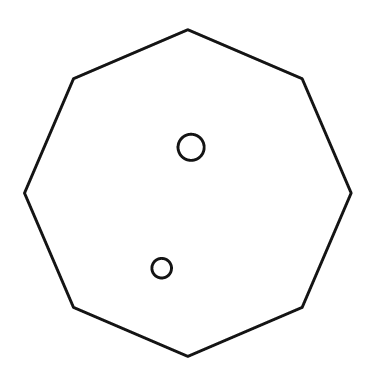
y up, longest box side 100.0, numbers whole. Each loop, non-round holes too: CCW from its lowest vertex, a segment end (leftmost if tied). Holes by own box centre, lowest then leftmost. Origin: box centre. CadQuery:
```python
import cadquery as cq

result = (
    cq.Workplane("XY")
    .moveTo(0.0, -50.0)
    .lineTo(35.0, -35.0)
    .lineTo(50.0, 0.0)
    .lineTo(35.0, 35.0)
    .lineTo(0.0, 50.0)
    .lineTo(-35.0, 35.0)
    .lineTo(-50.0, 0.0)
    .lineTo(-35.0, -35.0)
    .close()
    .moveTo(-8.0, -23.0)
    .circle(3.0)
    .moveTo(1.0, 14.0)
    .circle(4.0)
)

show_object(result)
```